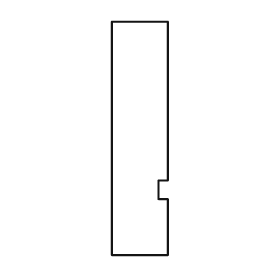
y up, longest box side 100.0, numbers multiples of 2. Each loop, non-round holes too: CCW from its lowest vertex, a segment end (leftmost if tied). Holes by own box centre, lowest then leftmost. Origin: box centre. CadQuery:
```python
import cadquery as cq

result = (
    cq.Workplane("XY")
    .moveTo(-12.0, -50.0)
    .lineTo(12.0, -50.0)
    .lineTo(12.0, -26.0)
    .lineTo(8.0, -26.0)
    .lineTo(8.0, -18.0)
    .lineTo(12.0, -18.0)
    .lineTo(12.0, 50.0)
    .lineTo(-12.0, 50.0)
    .close()
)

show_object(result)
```